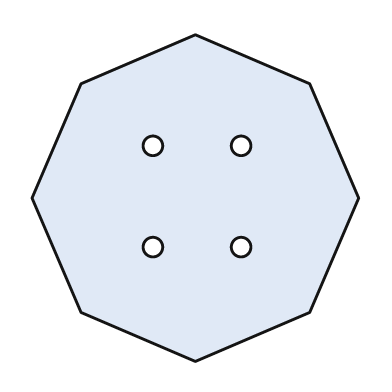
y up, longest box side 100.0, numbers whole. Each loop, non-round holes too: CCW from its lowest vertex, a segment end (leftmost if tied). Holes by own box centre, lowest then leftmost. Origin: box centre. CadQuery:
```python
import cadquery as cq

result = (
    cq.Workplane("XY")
    .moveTo(0.0, -50.0)
    .lineTo(35.0, -35.0)
    .lineTo(50.0, 0.0)
    .lineTo(35.0, 35.0)
    .lineTo(0.0, 50.0)
    .lineTo(-35.0, 35.0)
    .lineTo(-50.0, 0.0)
    .lineTo(-35.0, -35.0)
    .close()
    .moveTo(-13.0, -15.0)
    .circle(3.0)
    .moveTo(14.0, -15.0)
    .circle(3.0)
    .moveTo(-13.0, 16.0)
    .circle(3.0)
    .moveTo(14.0, 16.0)
    .circle(3.0)
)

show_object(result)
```